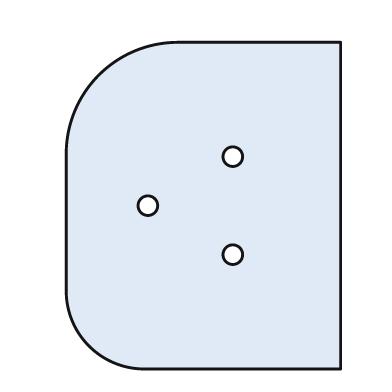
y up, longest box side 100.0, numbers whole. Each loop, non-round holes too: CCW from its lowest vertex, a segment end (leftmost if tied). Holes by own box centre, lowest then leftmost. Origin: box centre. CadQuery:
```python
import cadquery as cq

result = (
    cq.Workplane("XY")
    .moveTo(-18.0, -50.0)
    .lineTo(42.0, -50.0)
    .lineTo(42.0, 50.0)
    .lineTo(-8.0, 50.0)
    .threePointArc((-32.0, 40.0), (-42.0, 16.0))
    .lineTo(-42.0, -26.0)
    .threePointArc((-35.0, -43.0), (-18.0, -50.0))
    .close()
    .moveTo(9.0, -15.0)
    .circle(3.0)
    .moveTo(-17.0, 0.0)
    .circle(3.0)
    .moveTo(9.0, 15.0)
    .circle(3.0)
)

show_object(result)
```